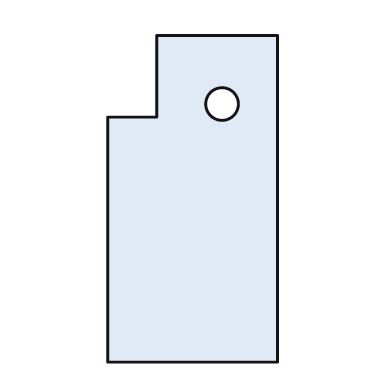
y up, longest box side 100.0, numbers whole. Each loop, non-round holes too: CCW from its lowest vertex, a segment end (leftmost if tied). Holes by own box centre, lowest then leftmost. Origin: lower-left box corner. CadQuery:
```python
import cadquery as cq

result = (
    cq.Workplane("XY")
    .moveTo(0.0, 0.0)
    .lineTo(52.0, 0.0)
    .lineTo(52.0, 100.0)
    .lineTo(15.0, 100.0)
    .lineTo(15.0, 75.0)
    .lineTo(0.0, 75.0)
    .close()
    .moveTo(35.0, 79.0)
    .circle(5.0)
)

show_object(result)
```